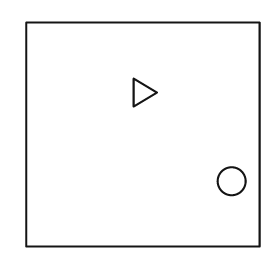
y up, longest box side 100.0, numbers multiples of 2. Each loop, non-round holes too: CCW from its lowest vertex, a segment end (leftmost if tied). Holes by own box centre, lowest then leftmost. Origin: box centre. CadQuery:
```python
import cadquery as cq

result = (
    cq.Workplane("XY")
    .moveTo(-50.0, -48.0)
    .lineTo(50.0, -48.0)
    .lineTo(50.0, 48.0)
    .lineTo(-50.0, 48.0)
    .close()
    .moveTo(38.0, -20.0)
    .circle(6.0)
    .moveTo(-4.0, 12.0)
    .lineTo(6.0, 18.0)
    .lineTo(-4.0, 24.0)
    .close()
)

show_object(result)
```